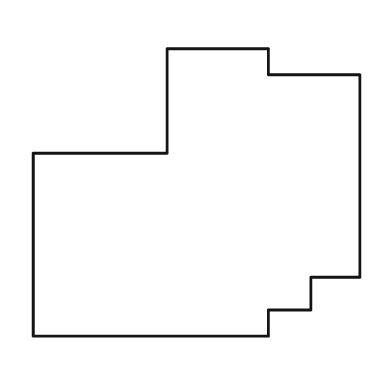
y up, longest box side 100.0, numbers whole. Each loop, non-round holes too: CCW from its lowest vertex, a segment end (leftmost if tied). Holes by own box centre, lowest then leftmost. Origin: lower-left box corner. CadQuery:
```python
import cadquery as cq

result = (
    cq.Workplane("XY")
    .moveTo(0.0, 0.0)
    .lineTo(72.0, 0.0)
    .lineTo(72.0, 8.0)
    .lineTo(85.0, 8.0)
    .lineTo(85.0, 18.0)
    .lineTo(100.0, 18.0)
    .lineTo(100.0, 80.0)
    .lineTo(72.0, 80.0)
    .lineTo(72.0, 88.0)
    .lineTo(41.0, 88.0)
    .lineTo(41.0, 56.0)
    .lineTo(0.0, 56.0)
    .close()
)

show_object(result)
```